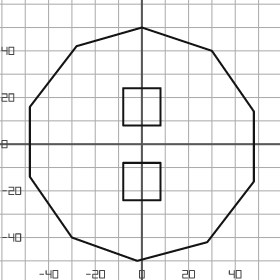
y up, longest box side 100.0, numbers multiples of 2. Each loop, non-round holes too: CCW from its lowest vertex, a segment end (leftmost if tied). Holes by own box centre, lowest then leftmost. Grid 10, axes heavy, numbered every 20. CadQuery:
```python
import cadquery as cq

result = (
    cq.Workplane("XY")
    .moveTo(-2.0, -50.0)
    .lineTo(28.0, -42.0)
    .lineTo(48.0, -16.0)
    .lineTo(48.0, 14.0)
    .lineTo(30.0, 40.0)
    .lineTo(0.0, 50.0)
    .lineTo(-28.0, 42.0)
    .lineTo(-48.0, 16.0)
    .lineTo(-48.0, -14.0)
    .lineTo(-30.0, -40.0)
    .close()
    .moveTo(-8.0, -24.0)
    .lineTo(8.0, -24.0)
    .lineTo(8.0, -8.0)
    .lineTo(-8.0, -8.0)
    .close()
    .moveTo(-8.0, 8.0)
    .lineTo(8.0, 8.0)
    .lineTo(8.0, 24.0)
    .lineTo(-8.0, 24.0)
    .close()
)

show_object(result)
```